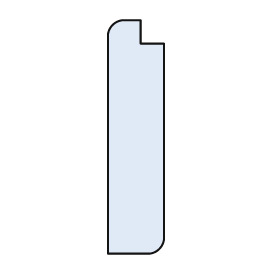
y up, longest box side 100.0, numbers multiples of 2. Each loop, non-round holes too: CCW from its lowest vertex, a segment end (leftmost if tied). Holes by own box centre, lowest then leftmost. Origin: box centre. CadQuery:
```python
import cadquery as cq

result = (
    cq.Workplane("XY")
    .moveTo(-12.0, -50.0)
    .lineTo(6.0, -50.0)
    .threePointArc((10.0, -48.0), (12.0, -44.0))
    .lineTo(12.0, 40.0)
    .lineTo(2.0, 40.0)
    .lineTo(2.0, 50.0)
    .lineTo(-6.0, 50.0)
    .threePointArc((-10.0, 48.0), (-12.0, 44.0))
    .close()
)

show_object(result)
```